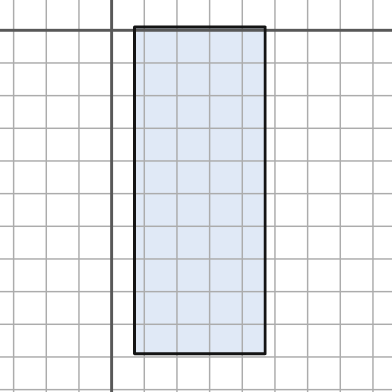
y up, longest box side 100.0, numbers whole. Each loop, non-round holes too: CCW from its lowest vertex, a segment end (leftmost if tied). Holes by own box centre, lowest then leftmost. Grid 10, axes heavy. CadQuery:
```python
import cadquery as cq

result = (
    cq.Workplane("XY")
    .moveTo(7.0, -99.0)
    .lineTo(47.0, -99.0)
    .lineTo(47.0, 1.0)
    .lineTo(7.0, 1.0)
    .close()
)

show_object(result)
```